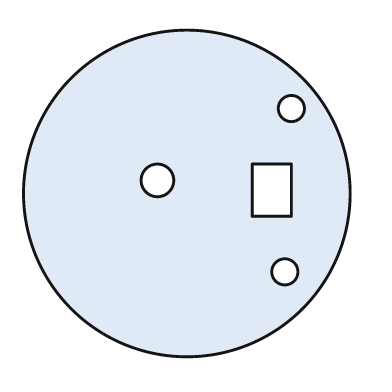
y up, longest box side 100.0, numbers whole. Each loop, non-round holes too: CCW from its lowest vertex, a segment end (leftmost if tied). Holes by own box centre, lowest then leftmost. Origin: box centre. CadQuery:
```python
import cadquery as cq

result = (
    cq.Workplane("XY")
    .moveTo(0.0, 0.0)
    .circle(50.0)
    .moveTo(30.0, -24.0)
    .circle(4.0)
    .moveTo(20.0, -7.0)
    .lineTo(32.0, -7.0)
    .lineTo(32.0, 9.0)
    .lineTo(20.0, 9.0)
    .close()
    .moveTo(-9.0, 4.0)
    .circle(5.0)
    .moveTo(32.0, 26.0)
    .circle(4.0)
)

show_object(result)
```